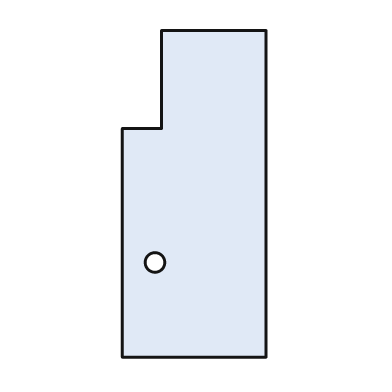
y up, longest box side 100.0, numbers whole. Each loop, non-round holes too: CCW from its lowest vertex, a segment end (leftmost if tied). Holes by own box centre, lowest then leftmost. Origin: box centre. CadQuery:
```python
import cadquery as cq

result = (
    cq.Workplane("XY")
    .moveTo(-22.0, -50.0)
    .lineTo(22.0, -50.0)
    .lineTo(22.0, 50.0)
    .lineTo(-10.0, 50.0)
    .lineTo(-10.0, 20.0)
    .lineTo(-22.0, 20.0)
    .close()
    .moveTo(-12.0, -21.0)
    .circle(3.0)
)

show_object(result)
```